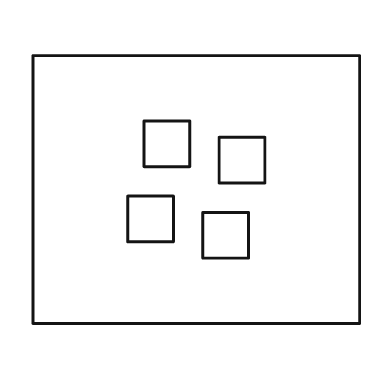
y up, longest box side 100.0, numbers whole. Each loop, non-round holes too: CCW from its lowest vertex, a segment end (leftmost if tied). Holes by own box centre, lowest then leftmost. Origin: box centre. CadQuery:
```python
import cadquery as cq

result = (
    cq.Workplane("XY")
    .moveTo(-50.0, -41.0)
    .lineTo(50.0, -41.0)
    .lineTo(50.0, 41.0)
    .lineTo(-50.0, 41.0)
    .close()
    .moveTo(2.0, -21.0)
    .lineTo(16.0, -21.0)
    .lineTo(16.0, -7.0)
    .lineTo(2.0, -7.0)
    .close()
    .moveTo(-21.0, -16.0)
    .lineTo(-7.0, -16.0)
    .lineTo(-7.0, -2.0)
    .lineTo(-21.0, -2.0)
    .close()
    .moveTo(7.0, 2.0)
    .lineTo(21.0, 2.0)
    .lineTo(21.0, 16.0)
    .lineTo(7.0, 16.0)
    .close()
    .moveTo(-16.0, 7.0)
    .lineTo(-2.0, 7.0)
    .lineTo(-2.0, 21.0)
    .lineTo(-16.0, 21.0)
    .close()
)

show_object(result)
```